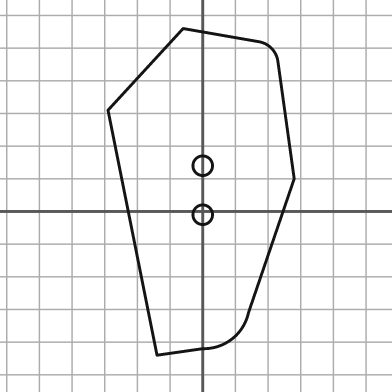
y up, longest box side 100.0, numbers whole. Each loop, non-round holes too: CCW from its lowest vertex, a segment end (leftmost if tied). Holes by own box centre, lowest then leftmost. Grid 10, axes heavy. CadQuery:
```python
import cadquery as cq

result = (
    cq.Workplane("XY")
    .moveTo(-14.0, -44.0)
    .lineTo(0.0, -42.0)
    .threePointArc((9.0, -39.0), (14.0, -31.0))
    .lineTo(28.0, 10.0)
    .lineTo(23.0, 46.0)
    .threePointArc((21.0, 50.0), (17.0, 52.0))
    .lineTo(-6.0, 56.0)
    .lineTo(-29.0, 31.0)
    .close()
    .moveTo(0.0, -1.0)
    .circle(3.0)
    .moveTo(0.0, 14.0)
    .circle(3.0)
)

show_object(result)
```